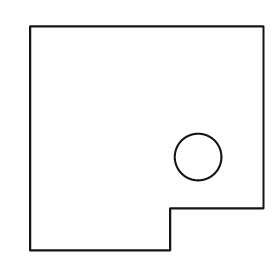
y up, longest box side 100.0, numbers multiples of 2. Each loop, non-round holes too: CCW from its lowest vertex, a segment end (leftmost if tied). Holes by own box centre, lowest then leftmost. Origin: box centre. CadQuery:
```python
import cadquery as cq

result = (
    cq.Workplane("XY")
    .moveTo(-50.0, -48.0)
    .lineTo(10.0, -48.0)
    .lineTo(10.0, -30.0)
    .lineTo(50.0, -30.0)
    .lineTo(50.0, 48.0)
    .lineTo(-50.0, 48.0)
    .close()
    .moveTo(22.0, -8.0)
    .circle(10.0)
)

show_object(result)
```